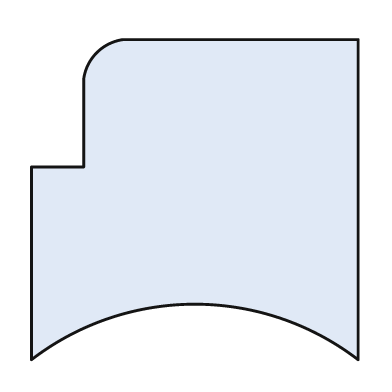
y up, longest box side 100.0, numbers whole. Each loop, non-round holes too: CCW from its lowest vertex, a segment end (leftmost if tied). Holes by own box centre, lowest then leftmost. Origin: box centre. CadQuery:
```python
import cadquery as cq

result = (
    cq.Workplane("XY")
    .moveTo(-50.0, -49.0)
    .threePointArc((0.0, -32.0), (50.0, -49.0))
    .lineTo(50.0, 49.0)
    .lineTo(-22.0, 49.0)
    .threePointArc((-30.0, 45.0), (-34.0, 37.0))
    .lineTo(-34.0, 10.0)
    .lineTo(-50.0, 10.0)
    .close()
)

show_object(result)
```